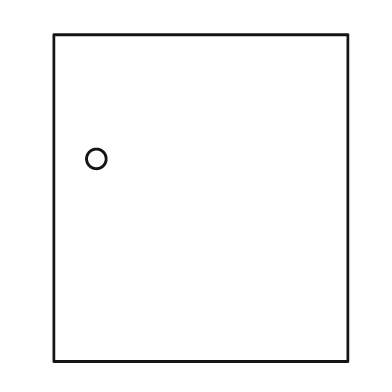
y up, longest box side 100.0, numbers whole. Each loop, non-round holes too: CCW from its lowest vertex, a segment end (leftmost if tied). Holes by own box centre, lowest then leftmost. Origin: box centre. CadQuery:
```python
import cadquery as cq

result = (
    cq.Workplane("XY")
    .moveTo(-45.0, -50.0)
    .lineTo(45.0, -50.0)
    .lineTo(45.0, 50.0)
    .lineTo(-45.0, 50.0)
    .close()
    .moveTo(-32.0, 12.0)
    .circle(3.0)
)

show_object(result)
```